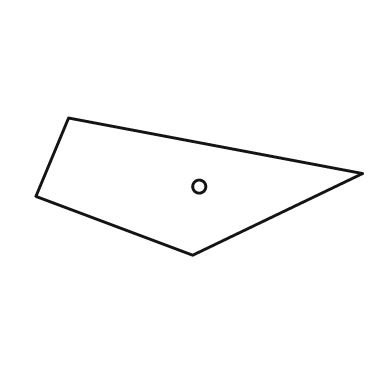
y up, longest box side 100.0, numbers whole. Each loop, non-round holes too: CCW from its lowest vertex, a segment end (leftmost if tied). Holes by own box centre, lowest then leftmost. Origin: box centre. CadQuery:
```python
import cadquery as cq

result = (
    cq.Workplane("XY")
    .moveTo(-2.0, -21.0)
    .lineTo(50.0, 4.0)
    .lineTo(-40.0, 21.0)
    .lineTo(-50.0, -3.0)
    .close()
    .moveTo(0.0, 0.0)
    .circle(2.0)
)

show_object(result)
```